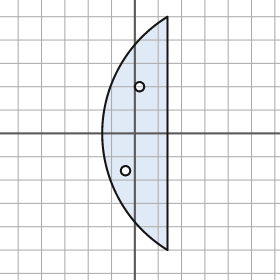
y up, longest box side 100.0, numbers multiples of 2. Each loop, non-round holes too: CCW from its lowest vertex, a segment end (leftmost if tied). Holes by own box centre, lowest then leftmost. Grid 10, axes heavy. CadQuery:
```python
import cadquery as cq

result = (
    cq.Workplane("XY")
    .moveTo(14.0, -50.0)
    .lineTo(14.0, 50.0)
    .threePointArc((-14.0, 0.0), (14.0, -50.0))
    .close()
    .moveTo(-4.0, -16.0)
    .circle(2.0)
    .moveTo(2.0, 20.0)
    .circle(2.0)
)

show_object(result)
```